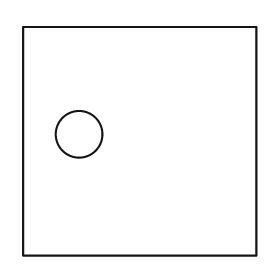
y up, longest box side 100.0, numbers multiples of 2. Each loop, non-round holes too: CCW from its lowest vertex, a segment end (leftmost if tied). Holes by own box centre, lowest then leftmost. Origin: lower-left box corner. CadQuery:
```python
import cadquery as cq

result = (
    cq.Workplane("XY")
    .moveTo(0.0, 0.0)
    .lineTo(100.0, 0.0)
    .lineTo(100.0, 98.0)
    .lineTo(0.0, 98.0)
    .close()
    .moveTo(24.0, 52.0)
    .circle(10.0)
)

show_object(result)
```